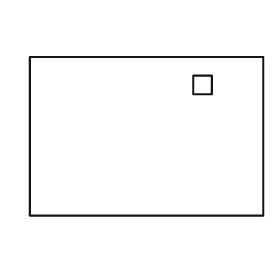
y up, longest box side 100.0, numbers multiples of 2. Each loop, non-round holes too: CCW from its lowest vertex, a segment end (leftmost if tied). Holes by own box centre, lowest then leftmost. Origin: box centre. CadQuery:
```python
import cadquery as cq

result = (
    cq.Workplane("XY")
    .moveTo(-50.0, -34.0)
    .lineTo(50.0, -34.0)
    .lineTo(50.0, 34.0)
    .lineTo(-50.0, 34.0)
    .close()
    .moveTo(20.0, 18.0)
    .lineTo(28.0, 18.0)
    .lineTo(28.0, 26.0)
    .lineTo(20.0, 26.0)
    .close()
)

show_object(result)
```